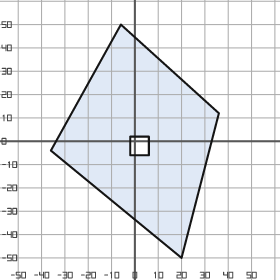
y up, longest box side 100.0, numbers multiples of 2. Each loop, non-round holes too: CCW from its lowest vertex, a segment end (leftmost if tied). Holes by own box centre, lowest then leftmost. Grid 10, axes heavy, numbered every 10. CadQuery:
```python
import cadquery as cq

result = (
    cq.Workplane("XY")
    .moveTo(20.0, -50.0)
    .lineTo(36.0, 12.0)
    .lineTo(-6.0, 50.0)
    .lineTo(-36.0, -4.0)
    .close()
    .moveTo(-2.0, -6.0)
    .lineTo(6.0, -6.0)
    .lineTo(6.0, 2.0)
    .lineTo(-2.0, 2.0)
    .close()
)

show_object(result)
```